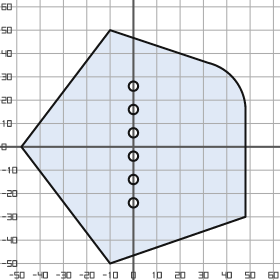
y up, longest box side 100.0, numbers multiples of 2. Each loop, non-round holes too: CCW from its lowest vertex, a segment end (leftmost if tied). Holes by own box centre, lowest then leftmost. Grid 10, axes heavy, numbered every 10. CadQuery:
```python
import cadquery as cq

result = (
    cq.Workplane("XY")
    .moveTo(-10.0, -50.0)
    .lineTo(48.0, -30.0)
    .lineTo(48.0, 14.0)
    .threePointArc((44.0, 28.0), (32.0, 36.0))
    .lineTo(-10.0, 50.0)
    .lineTo(-48.0, 0.0)
    .close()
    .moveTo(0.0, -24.0)
    .circle(2.0)
    .moveTo(0.0, -14.0)
    .circle(2.0)
    .moveTo(0.0, -4.0)
    .circle(2.0)
    .moveTo(0.0, 6.0)
    .circle(2.0)
    .moveTo(0.0, 16.0)
    .circle(2.0)
    .moveTo(0.0, 26.0)
    .circle(2.0)
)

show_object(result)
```